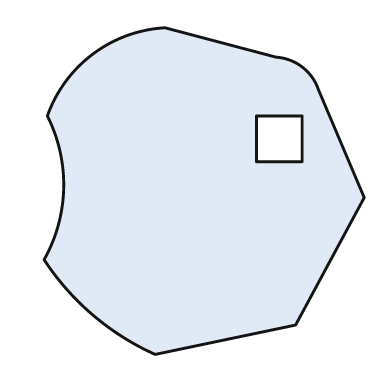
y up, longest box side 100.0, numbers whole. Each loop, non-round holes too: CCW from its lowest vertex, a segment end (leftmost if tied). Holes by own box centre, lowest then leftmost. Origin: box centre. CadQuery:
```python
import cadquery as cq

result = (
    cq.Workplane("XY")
    .moveTo(-15.0, -50.0)
    .lineTo(28.0, -41.0)
    .lineTo(49.0, -2.0)
    .lineTo(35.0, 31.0)
    .threePointArc((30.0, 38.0), (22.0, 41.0))
    .lineTo(-12.0, 50.0)
    .threePointArc((-34.0, 42.0), (-48.0, 23.0))
    .threePointArc((-43.0, 1.0), (-49.0, -21.0))
    .threePointArc((-34.0, -38.0), (-15.0, -50.0))
    .close()
    .moveTo(16.0, 9.0)
    .lineTo(30.0, 9.0)
    .lineTo(30.0, 23.0)
    .lineTo(16.0, 23.0)
    .close()
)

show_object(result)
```